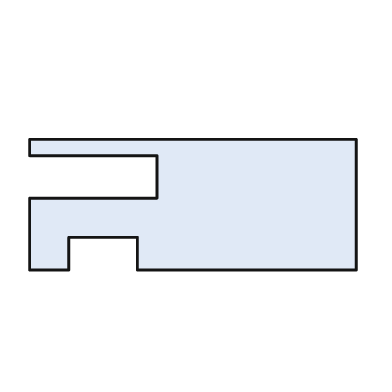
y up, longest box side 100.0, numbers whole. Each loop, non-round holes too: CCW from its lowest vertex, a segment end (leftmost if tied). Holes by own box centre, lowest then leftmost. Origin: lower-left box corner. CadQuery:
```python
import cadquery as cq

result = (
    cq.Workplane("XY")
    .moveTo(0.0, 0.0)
    .lineTo(12.0, 0.0)
    .lineTo(12.0, 10.0)
    .lineTo(33.0, 10.0)
    .lineTo(33.0, 0.0)
    .lineTo(100.0, 0.0)
    .lineTo(100.0, 40.0)
    .lineTo(0.0, 40.0)
    .lineTo(0.0, 35.0)
    .lineTo(39.0, 35.0)
    .lineTo(39.0, 22.0)
    .lineTo(0.0, 22.0)
    .close()
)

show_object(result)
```